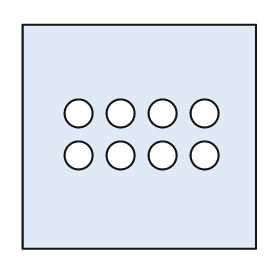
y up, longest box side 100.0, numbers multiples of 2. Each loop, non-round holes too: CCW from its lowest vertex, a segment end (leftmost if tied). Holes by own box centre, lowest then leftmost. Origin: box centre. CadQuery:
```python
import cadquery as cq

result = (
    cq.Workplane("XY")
    .moveTo(-50.0, -48.0)
    .lineTo(50.0, -48.0)
    .lineTo(50.0, 48.0)
    .lineTo(-50.0, 48.0)
    .close()
    .moveTo(-26.0, -8.0)
    .circle(6.0)
    .moveTo(-8.0, -8.0)
    .circle(6.0)
    .moveTo(10.0, -8.0)
    .circle(6.0)
    .moveTo(28.0, -8.0)
    .circle(6.0)
    .moveTo(-26.0, 10.0)
    .circle(6.0)
    .moveTo(-8.0, 10.0)
    .circle(6.0)
    .moveTo(10.0, 10.0)
    .circle(6.0)
    .moveTo(28.0, 10.0)
    .circle(6.0)
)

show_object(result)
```